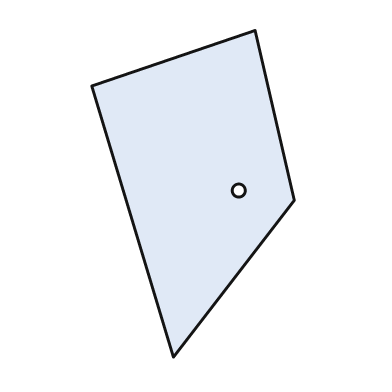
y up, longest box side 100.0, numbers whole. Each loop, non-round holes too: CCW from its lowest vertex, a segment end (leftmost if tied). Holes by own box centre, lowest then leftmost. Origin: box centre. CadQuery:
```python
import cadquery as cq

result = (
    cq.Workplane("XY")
    .moveTo(-6.0, -50.0)
    .lineTo(31.0, -2.0)
    .lineTo(19.0, 50.0)
    .lineTo(-31.0, 33.0)
    .close()
    .moveTo(14.0, 1.0)
    .circle(2.0)
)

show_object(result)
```